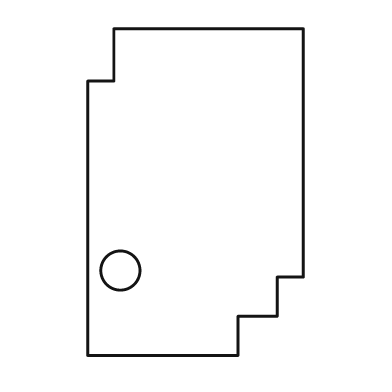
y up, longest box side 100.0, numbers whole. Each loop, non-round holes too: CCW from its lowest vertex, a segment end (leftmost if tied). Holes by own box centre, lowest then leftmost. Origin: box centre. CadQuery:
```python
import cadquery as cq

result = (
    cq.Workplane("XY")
    .moveTo(-33.0, -50.0)
    .lineTo(13.0, -50.0)
    .lineTo(13.0, -38.0)
    .lineTo(25.0, -38.0)
    .lineTo(25.0, -26.0)
    .lineTo(33.0, -26.0)
    .lineTo(33.0, 50.0)
    .lineTo(-25.0, 50.0)
    .lineTo(-25.0, 34.0)
    .lineTo(-33.0, 34.0)
    .close()
    .moveTo(-23.0, -24.0)
    .circle(6.0)
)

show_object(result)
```